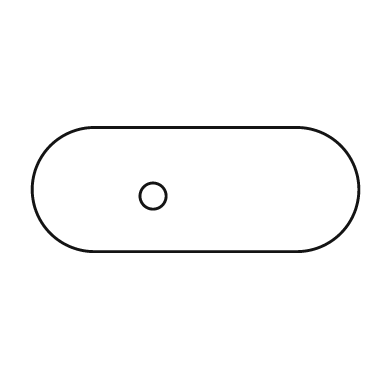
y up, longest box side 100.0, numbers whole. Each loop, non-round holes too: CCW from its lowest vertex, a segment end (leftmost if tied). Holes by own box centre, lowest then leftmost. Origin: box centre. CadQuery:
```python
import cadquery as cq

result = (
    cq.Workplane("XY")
    .moveTo(-31.0, -19.0)
    .lineTo(31.0, -19.0)
    .threePointArc((50.0, 0.0), (31.0, 19.0))
    .lineTo(-31.0, 19.0)
    .threePointArc((-50.0, 0.0), (-31.0, -19.0))
    .close()
    .moveTo(-13.0, -2.0)
    .circle(4.0)
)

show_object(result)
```